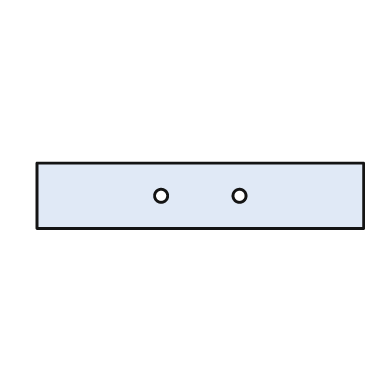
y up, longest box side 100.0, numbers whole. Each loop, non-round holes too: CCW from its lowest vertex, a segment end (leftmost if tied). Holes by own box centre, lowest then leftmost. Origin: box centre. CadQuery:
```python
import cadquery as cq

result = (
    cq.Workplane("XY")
    .moveTo(-50.0, -10.0)
    .lineTo(50.0, -10.0)
    .lineTo(50.0, 10.0)
    .lineTo(-50.0, 10.0)
    .close()
    .moveTo(-12.0, 0.0)
    .circle(2.0)
    .moveTo(12.0, 0.0)
    .circle(2.0)
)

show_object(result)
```